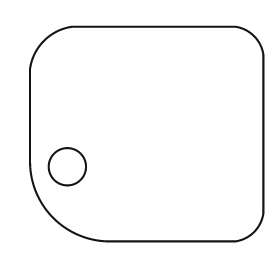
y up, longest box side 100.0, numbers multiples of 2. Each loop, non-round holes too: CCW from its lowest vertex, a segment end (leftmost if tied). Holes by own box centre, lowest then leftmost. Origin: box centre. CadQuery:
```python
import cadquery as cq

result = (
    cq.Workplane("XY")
    .moveTo(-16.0, -46.0)
    .lineTo(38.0, -46.0)
    .threePointArc((46.0, -42.0), (50.0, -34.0))
    .lineTo(50.0, 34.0)
    .threePointArc((46.0, 42.0), (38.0, 46.0))
    .lineTo(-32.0, 46.0)
    .threePointArc((-44.0, 40.0), (-50.0, 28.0))
    .lineTo(-50.0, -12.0)
    .threePointArc((-40.0, -36.0), (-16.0, -46.0))
    .close()
    .moveTo(-34.0, -14.0)
    .circle(8.0)
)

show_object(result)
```